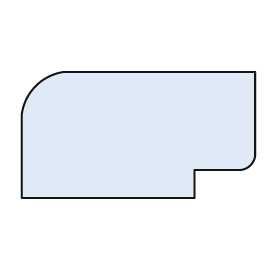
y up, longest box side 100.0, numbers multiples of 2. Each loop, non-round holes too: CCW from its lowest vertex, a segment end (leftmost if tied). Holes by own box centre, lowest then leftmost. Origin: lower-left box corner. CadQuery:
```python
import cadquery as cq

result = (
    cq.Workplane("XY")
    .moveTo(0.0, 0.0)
    .lineTo(74.0, 0.0)
    .lineTo(74.0, 12.0)
    .lineTo(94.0, 12.0)
    .threePointArc((98.0, 14.0), (100.0, 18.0))
    .lineTo(100.0, 54.0)
    .lineTo(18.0, 54.0)
    .threePointArc((6.0, 48.0), (0.0, 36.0))
    .close()
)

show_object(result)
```